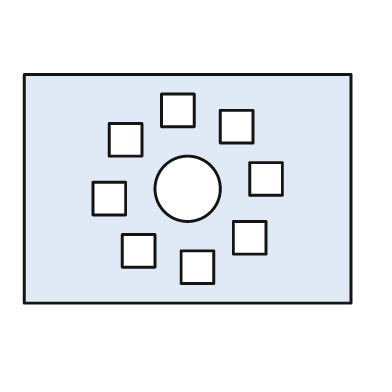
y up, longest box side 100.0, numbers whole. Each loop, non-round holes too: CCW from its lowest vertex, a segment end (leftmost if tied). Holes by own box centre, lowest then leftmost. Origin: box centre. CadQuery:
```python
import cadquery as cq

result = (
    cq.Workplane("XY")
    .moveTo(-50.0, -35.0)
    .lineTo(50.0, -35.0)
    .lineTo(50.0, 35.0)
    .lineTo(-50.0, 35.0)
    .close()
    .moveTo(-2.0, -29.0)
    .lineTo(8.0, -29.0)
    .lineTo(8.0, -19.0)
    .lineTo(-2.0, -19.0)
    .close()
    .moveTo(-20.0, -24.0)
    .lineTo(-10.0, -24.0)
    .lineTo(-10.0, -14.0)
    .lineTo(-20.0, -14.0)
    .close()
    .moveTo(14.0, -20.0)
    .lineTo(24.0, -20.0)
    .lineTo(24.0, -10.0)
    .lineTo(14.0, -10.0)
    .close()
    .moveTo(-29.0, -8.0)
    .lineTo(-19.0, -8.0)
    .lineTo(-19.0, 2.0)
    .lineTo(-29.0, 2.0)
    .close()
    .moveTo(0.0, 0.0)
    .circle(10.0)
    .moveTo(19.0, -2.0)
    .lineTo(29.0, -2.0)
    .lineTo(29.0, 8.0)
    .lineTo(19.0, 8.0)
    .close()
    .moveTo(-24.0, 10.0)
    .lineTo(-14.0, 10.0)
    .lineTo(-14.0, 20.0)
    .lineTo(-24.0, 20.0)
    .close()
    .moveTo(10.0, 14.0)
    .lineTo(20.0, 14.0)
    .lineTo(20.0, 24.0)
    .lineTo(10.0, 24.0)
    .close()
    .moveTo(-8.0, 19.0)
    .lineTo(2.0, 19.0)
    .lineTo(2.0, 29.0)
    .lineTo(-8.0, 29.0)
    .close()
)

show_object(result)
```